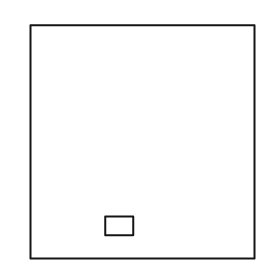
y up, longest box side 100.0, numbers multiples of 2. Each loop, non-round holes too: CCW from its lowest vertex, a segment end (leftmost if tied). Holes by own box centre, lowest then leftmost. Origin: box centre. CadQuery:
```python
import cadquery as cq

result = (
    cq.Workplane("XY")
    .moveTo(-48.0, -50.0)
    .lineTo(48.0, -50.0)
    .lineTo(48.0, 50.0)
    .lineTo(-48.0, 50.0)
    .close()
    .moveTo(-16.0, -40.0)
    .lineTo(-4.0, -40.0)
    .lineTo(-4.0, -32.0)
    .lineTo(-16.0, -32.0)
    .close()
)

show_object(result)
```